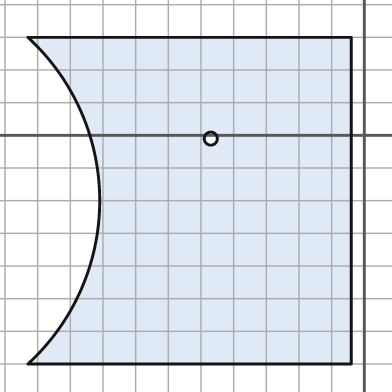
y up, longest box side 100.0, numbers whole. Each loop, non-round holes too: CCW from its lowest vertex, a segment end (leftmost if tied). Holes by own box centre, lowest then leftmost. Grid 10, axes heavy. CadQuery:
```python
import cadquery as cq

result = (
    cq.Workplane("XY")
    .moveTo(-103.0, -70.0)
    .lineTo(-4.0, -70.0)
    .lineTo(-4.0, 30.0)
    .lineTo(-103.0, 30.0)
    .threePointArc((-81.0, -20.0), (-103.0, -70.0))
    .close()
    .moveTo(-47.0, -1.0)
    .circle(2.0)
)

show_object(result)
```